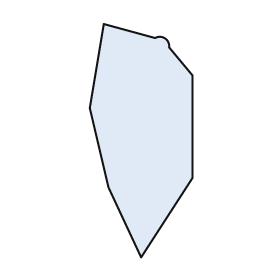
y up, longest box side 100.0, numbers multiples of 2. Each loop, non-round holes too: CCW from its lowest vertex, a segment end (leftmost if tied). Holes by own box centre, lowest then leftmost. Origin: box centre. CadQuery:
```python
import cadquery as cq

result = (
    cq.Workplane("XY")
    .moveTo(0.0, -50.0)
    .lineTo(22.0, -16.0)
    .lineTo(22.0, 28.0)
    .lineTo(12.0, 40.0)
    .threePointArc((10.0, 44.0), (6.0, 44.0))
    .lineTo(-16.0, 50.0)
    .lineTo(-22.0, 14.0)
    .lineTo(-14.0, -20.0)
    .close()
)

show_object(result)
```